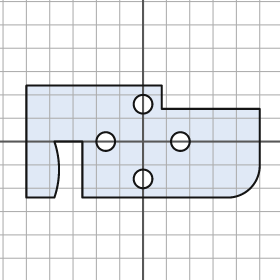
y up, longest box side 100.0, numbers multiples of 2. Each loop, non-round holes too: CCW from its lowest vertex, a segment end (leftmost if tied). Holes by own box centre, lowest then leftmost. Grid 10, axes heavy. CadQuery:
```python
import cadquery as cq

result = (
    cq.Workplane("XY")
    .moveTo(-50.0, -24.0)
    .lineTo(-38.0, -24.0)
    .threePointArc((-36.0, -12.0), (-38.0, 0.0))
    .lineTo(-26.0, 0.0)
    .lineTo(-26.0, -24.0)
    .lineTo(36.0, -24.0)
    .threePointArc((46.0, -20.0), (50.0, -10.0))
    .lineTo(50.0, 14.0)
    .lineTo(8.0, 14.0)
    .lineTo(8.0, 24.0)
    .lineTo(-50.0, 24.0)
    .close()
    .moveTo(0.0, -16.0)
    .circle(4.0)
    .moveTo(-16.0, 0.0)
    .circle(4.0)
    .moveTo(16.0, 0.0)
    .circle(4.0)
    .moveTo(0.0, 16.0)
    .circle(4.0)
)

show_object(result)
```